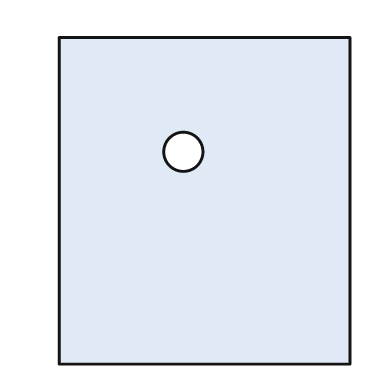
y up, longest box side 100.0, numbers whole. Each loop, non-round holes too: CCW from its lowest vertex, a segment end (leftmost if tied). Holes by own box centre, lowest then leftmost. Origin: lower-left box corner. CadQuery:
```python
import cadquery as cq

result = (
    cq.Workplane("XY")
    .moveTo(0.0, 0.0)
    .lineTo(89.0, 0.0)
    .lineTo(89.0, 100.0)
    .lineTo(0.0, 100.0)
    .close()
    .moveTo(38.0, 65.0)
    .circle(6.0)
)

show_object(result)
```